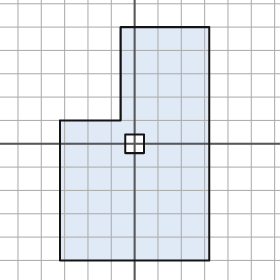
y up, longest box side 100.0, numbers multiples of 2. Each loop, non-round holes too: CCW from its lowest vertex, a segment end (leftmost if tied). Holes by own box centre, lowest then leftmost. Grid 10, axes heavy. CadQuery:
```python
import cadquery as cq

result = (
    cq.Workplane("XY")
    .moveTo(-32.0, -50.0)
    .lineTo(32.0, -50.0)
    .lineTo(32.0, 50.0)
    .lineTo(-6.0, 50.0)
    .lineTo(-6.0, 10.0)
    .lineTo(-32.0, 10.0)
    .close()
    .moveTo(-4.0, -4.0)
    .lineTo(4.0, -4.0)
    .lineTo(4.0, 4.0)
    .lineTo(-4.0, 4.0)
    .close()
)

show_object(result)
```